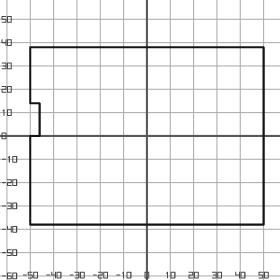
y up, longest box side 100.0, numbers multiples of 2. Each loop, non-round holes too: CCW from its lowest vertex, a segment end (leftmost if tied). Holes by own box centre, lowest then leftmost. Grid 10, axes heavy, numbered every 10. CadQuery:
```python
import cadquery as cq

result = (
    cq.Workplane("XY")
    .moveTo(-50.0, -38.0)
    .lineTo(50.0, -38.0)
    .lineTo(50.0, 38.0)
    .lineTo(-50.0, 38.0)
    .lineTo(-50.0, 14.0)
    .lineTo(-46.0, 14.0)
    .lineTo(-46.0, 0.0)
    .lineTo(-50.0, 0.0)
    .close()
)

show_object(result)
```